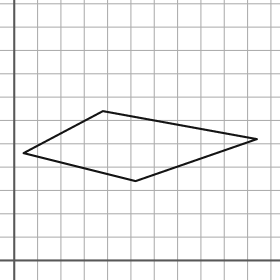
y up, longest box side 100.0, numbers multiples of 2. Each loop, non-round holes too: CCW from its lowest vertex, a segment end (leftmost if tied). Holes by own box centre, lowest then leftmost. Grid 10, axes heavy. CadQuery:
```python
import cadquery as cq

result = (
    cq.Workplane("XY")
    .moveTo(52.0, 34.0)
    .lineTo(104.0, 52.0)
    .lineTo(38.0, 64.0)
    .lineTo(4.0, 46.0)
    .close()
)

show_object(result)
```